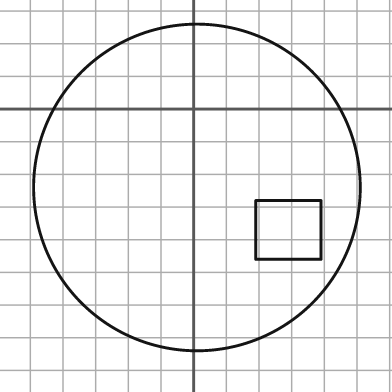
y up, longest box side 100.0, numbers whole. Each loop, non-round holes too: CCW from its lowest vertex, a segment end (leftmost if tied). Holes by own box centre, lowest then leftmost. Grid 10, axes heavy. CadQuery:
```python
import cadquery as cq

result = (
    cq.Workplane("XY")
    .moveTo(1.0, -24.0)
    .circle(50.0)
    .moveTo(19.0, -46.0)
    .lineTo(39.0, -46.0)
    .lineTo(39.0, -28.0)
    .lineTo(19.0, -28.0)
    .close()
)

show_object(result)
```